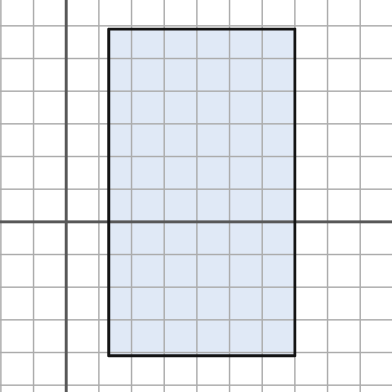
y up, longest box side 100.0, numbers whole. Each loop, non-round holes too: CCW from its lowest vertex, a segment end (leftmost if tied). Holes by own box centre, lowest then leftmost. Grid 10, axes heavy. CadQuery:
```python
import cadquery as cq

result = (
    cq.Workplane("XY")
    .moveTo(13.0, -41.0)
    .lineTo(70.0, -41.0)
    .lineTo(70.0, 59.0)
    .lineTo(13.0, 59.0)
    .close()
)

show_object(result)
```